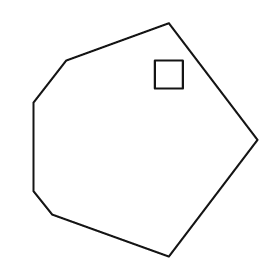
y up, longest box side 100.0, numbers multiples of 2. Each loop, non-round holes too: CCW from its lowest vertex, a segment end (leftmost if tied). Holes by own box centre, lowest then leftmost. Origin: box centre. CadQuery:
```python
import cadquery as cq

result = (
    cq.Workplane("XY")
    .moveTo(10.0, -50.0)
    .lineTo(48.0, 0.0)
    .lineTo(10.0, 50.0)
    .lineTo(-34.0, 34.0)
    .lineTo(-48.0, 16.0)
    .lineTo(-48.0, -22.0)
    .lineTo(-40.0, -32.0)
    .close()
    .moveTo(4.0, 22.0)
    .lineTo(16.0, 22.0)
    .lineTo(16.0, 34.0)
    .lineTo(4.0, 34.0)
    .close()
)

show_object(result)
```